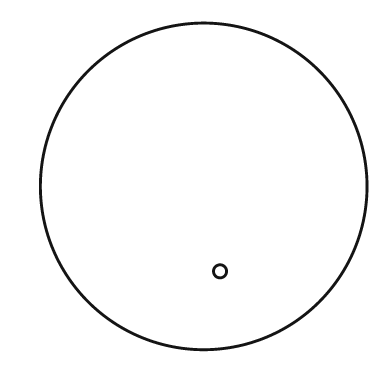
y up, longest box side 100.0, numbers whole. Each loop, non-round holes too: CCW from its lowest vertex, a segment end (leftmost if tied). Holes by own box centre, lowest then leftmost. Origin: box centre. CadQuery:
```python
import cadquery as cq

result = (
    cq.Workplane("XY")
    .moveTo(0.0, 0.0)
    .circle(50.0)
    .moveTo(5.0, -26.0)
    .circle(2.0)
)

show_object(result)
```